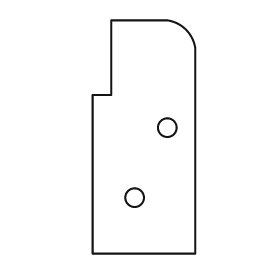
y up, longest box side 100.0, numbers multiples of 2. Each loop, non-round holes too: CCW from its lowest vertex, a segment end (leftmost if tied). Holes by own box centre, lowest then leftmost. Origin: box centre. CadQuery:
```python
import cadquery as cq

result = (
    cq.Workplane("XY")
    .moveTo(-22.0, -50.0)
    .lineTo(22.0, -50.0)
    .lineTo(22.0, 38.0)
    .threePointArc((18.0, 46.0), (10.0, 50.0))
    .lineTo(-14.0, 50.0)
    .lineTo(-14.0, 18.0)
    .lineTo(-22.0, 18.0)
    .close()
    .moveTo(-4.0, -26.0)
    .circle(4.0)
    .moveTo(10.0, 4.0)
    .circle(4.0)
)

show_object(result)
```